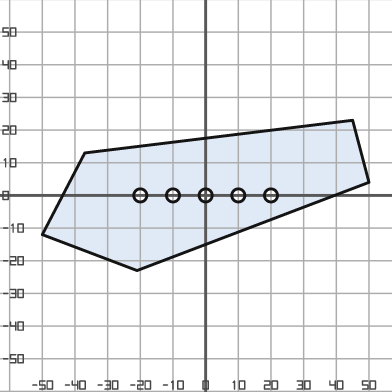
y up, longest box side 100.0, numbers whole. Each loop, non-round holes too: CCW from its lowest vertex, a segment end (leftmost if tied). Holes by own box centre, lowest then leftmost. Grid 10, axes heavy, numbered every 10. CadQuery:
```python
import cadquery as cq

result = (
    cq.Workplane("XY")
    .moveTo(-21.0, -23.0)
    .lineTo(50.0, 4.0)
    .lineTo(45.0, 23.0)
    .lineTo(-37.0, 13.0)
    .lineTo(-50.0, -12.0)
    .close()
    .moveTo(-20.0, 0.0)
    .circle(2.0)
    .moveTo(-10.0, 0.0)
    .circle(2.0)
    .moveTo(0.0, 0.0)
    .circle(2.0)
    .moveTo(10.0, 0.0)
    .circle(2.0)
    .moveTo(20.0, 0.0)
    .circle(2.0)
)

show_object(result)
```